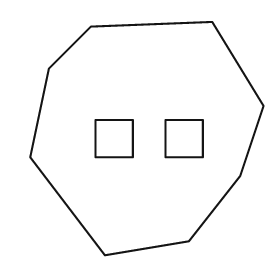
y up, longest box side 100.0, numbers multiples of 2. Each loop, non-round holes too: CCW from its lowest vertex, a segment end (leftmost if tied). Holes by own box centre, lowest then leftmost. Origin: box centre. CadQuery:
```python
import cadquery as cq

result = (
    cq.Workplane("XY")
    .moveTo(-18.0, -50.0)
    .lineTo(18.0, -44.0)
    .lineTo(40.0, -16.0)
    .lineTo(50.0, 14.0)
    .lineTo(28.0, 50.0)
    .lineTo(-24.0, 48.0)
    .lineTo(-42.0, 30.0)
    .lineTo(-50.0, -8.0)
    .close()
    .moveTo(-22.0, -8.0)
    .lineTo(-6.0, -8.0)
    .lineTo(-6.0, 8.0)
    .lineTo(-22.0, 8.0)
    .close()
    .moveTo(8.0, -8.0)
    .lineTo(24.0, -8.0)
    .lineTo(24.0, 8.0)
    .lineTo(8.0, 8.0)
    .close()
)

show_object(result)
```